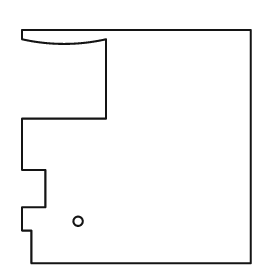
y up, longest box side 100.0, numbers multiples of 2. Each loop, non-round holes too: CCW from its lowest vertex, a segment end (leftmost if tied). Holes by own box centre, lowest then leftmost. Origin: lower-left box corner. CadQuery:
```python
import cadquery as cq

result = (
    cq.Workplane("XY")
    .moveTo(4.0, 0.0)
    .lineTo(98.0, 0.0)
    .lineTo(98.0, 100.0)
    .lineTo(0.0, 100.0)
    .lineTo(0.0, 96.0)
    .threePointArc((18.0, 94.0), (36.0, 96.0))
    .lineTo(36.0, 62.0)
    .lineTo(0.0, 62.0)
    .lineTo(0.0, 40.0)
    .lineTo(10.0, 40.0)
    .lineTo(10.0, 24.0)
    .lineTo(0.0, 24.0)
    .lineTo(0.0, 14.0)
    .lineTo(4.0, 14.0)
    .close()
    .moveTo(24.0, 18.0)
    .circle(2.0)
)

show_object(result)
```